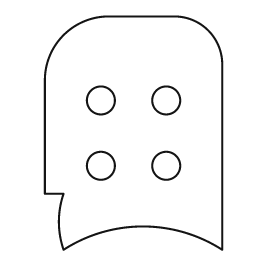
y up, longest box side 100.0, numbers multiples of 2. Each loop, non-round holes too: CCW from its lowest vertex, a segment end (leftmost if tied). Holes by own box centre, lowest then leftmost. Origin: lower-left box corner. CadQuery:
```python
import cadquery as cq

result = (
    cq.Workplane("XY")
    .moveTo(8.0, 0.0)
    .threePointArc((42.0, 10.0), (76.0, 0.0))
    .lineTo(76.0, 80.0)
    .threePointArc((70.0, 94.0), (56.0, 100.0))
    .lineTo(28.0, 100.0)
    .threePointArc((8.0, 92.0), (0.0, 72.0))
    .lineTo(0.0, 24.0)
    .lineTo(8.0, 24.0)
    .threePointArc((6.0, 12.0), (8.0, 0.0))
    .close()
    .moveTo(24.0, 36.0)
    .circle(6.0)
    .moveTo(52.0, 36.0)
    .circle(6.0)
    .moveTo(24.0, 64.0)
    .circle(6.0)
    .moveTo(52.0, 64.0)
    .circle(6.0)
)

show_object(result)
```